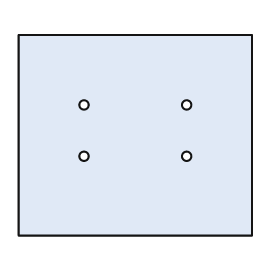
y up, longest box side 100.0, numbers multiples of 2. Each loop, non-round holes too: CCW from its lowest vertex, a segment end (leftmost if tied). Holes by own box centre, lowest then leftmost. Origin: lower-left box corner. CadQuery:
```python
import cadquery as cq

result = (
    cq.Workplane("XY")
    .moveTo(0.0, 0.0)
    .lineTo(100.0, 0.0)
    .lineTo(100.0, 86.0)
    .lineTo(0.0, 86.0)
    .close()
    .moveTo(28.0, 34.0)
    .circle(2.0)
    .moveTo(72.0, 34.0)
    .circle(2.0)
    .moveTo(28.0, 56.0)
    .circle(2.0)
    .moveTo(72.0, 56.0)
    .circle(2.0)
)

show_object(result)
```